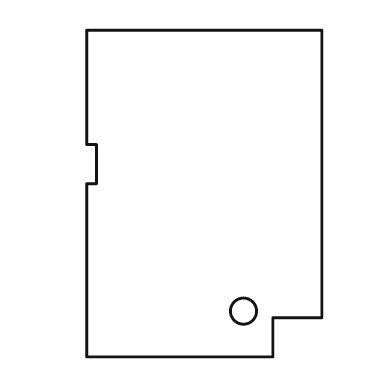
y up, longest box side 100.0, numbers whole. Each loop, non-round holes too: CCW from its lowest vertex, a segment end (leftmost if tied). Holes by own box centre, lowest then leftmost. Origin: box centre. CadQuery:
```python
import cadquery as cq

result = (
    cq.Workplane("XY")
    .moveTo(-36.0, -50.0)
    .lineTo(21.0, -50.0)
    .lineTo(21.0, -38.0)
    .lineTo(36.0, -38.0)
    .lineTo(36.0, 50.0)
    .lineTo(-36.0, 50.0)
    .lineTo(-36.0, 15.0)
    .lineTo(-33.0, 15.0)
    .lineTo(-33.0, 3.0)
    .lineTo(-36.0, 3.0)
    .close()
    .moveTo(12.0, -36.0)
    .circle(4.0)
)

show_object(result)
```